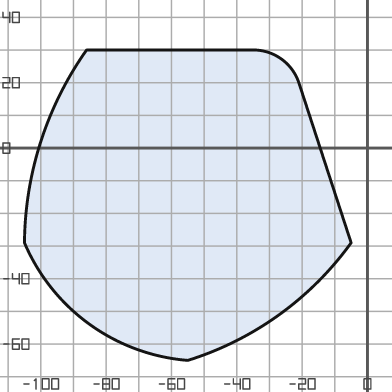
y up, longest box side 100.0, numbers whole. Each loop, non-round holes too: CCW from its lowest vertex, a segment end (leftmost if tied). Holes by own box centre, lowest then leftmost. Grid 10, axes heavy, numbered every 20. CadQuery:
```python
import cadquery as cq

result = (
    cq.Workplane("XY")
    .moveTo(-55.0, -65.0)
    .threePointArc((-27.0, -51.0), (-5.0, -29.0))
    .lineTo(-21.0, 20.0)
    .threePointArc((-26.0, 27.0), (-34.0, 30.0))
    .lineTo(-86.0, 30.0)
    .threePointArc((-100.0, 2.0), (-105.0, -29.0))
    .threePointArc((-85.0, -54.0), (-55.0, -65.0))
    .close()
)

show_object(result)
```